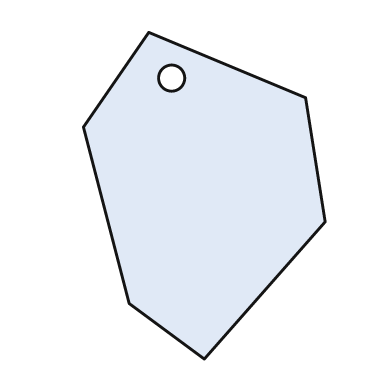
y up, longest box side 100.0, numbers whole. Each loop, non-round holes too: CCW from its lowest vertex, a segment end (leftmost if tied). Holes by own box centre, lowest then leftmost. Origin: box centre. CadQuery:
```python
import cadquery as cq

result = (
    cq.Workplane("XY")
    .moveTo(0.0, -50.0)
    .lineTo(37.0, -8.0)
    .lineTo(31.0, 30.0)
    .lineTo(-17.0, 50.0)
    .lineTo(-37.0, 21.0)
    .lineTo(-23.0, -33.0)
    .close()
    .moveTo(-10.0, 36.0)
    .circle(4.0)
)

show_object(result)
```